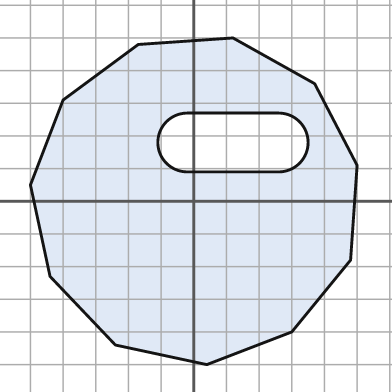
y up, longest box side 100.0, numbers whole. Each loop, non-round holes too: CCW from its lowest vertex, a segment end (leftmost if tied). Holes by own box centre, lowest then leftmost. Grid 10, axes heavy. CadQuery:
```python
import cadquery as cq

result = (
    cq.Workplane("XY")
    .moveTo(4.0, -50.0)
    .lineTo(30.0, -40.0)
    .lineTo(48.0, -18.0)
    .lineTo(50.0, 11.0)
    .lineTo(37.0, 36.0)
    .lineTo(12.0, 50.0)
    .lineTo(-17.0, 48.0)
    .lineTo(-40.0, 31.0)
    .lineTo(-50.0, 5.0)
    .lineTo(-44.0, -23.0)
    .lineTo(-24.0, -44.0)
    .close()
    .moveTo(-2.0, 9.0)
    .lineTo(26.0, 9.0)
    .threePointArc((35.0, 18.0), (26.0, 27.0))
    .lineTo(-2.0, 27.0)
    .threePointArc((-11.0, 18.0), (-2.0, 9.0))
    .close()
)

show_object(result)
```